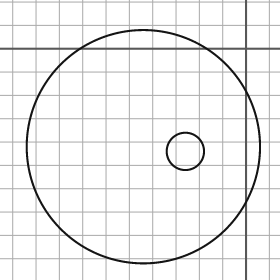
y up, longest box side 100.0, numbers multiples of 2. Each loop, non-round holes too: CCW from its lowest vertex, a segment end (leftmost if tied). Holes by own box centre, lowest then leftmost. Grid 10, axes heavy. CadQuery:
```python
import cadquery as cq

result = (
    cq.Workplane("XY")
    .moveTo(-44.0, -42.0)
    .circle(50.0)
    .moveTo(-26.0, -44.0)
    .circle(8.0)
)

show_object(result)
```